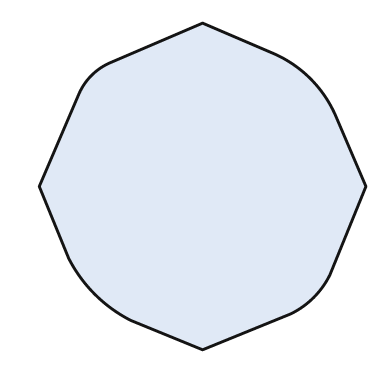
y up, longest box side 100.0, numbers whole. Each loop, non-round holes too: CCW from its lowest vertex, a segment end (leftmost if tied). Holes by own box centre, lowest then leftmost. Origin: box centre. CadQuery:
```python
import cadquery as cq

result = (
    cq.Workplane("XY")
    .moveTo(0.0, -50.0)
    .lineTo(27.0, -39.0)
    .threePointArc((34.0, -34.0), (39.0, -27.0))
    .lineTo(50.0, 0.0)
    .lineTo(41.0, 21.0)
    .threePointArc((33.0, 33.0), (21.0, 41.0))
    .lineTo(0.0, 50.0)
    .lineTo(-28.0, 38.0)
    .threePointArc((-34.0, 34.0), (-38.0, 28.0))
    .lineTo(-50.0, 0.0)
    .lineTo(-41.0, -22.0)
    .threePointArc((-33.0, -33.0), (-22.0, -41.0))
    .close()
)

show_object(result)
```